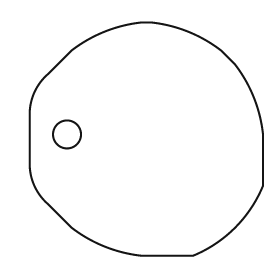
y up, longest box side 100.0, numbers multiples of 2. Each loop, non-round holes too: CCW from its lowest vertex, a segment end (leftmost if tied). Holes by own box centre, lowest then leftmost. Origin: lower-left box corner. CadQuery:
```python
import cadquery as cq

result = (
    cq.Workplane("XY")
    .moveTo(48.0, 0.0)
    .lineTo(70.0, 0.0)
    .threePointArc((88.0, 12.0), (100.0, 30.0))
    .lineTo(100.0, 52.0)
    .threePointArc((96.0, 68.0), (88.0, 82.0))
    .lineTo(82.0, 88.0)
    .threePointArc((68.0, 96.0), (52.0, 100.0))
    .lineTo(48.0, 100.0)
    .threePointArc((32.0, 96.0), (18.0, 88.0))
    .lineTo(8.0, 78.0)
    .threePointArc((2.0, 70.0), (0.0, 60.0))
    .lineTo(0.0, 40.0)
    .threePointArc((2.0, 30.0), (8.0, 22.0))
    .lineTo(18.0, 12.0)
    .threePointArc((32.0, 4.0), (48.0, 0.0))
    .close()
    .moveTo(16.0, 52.0)
    .circle(6.0)
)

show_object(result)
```